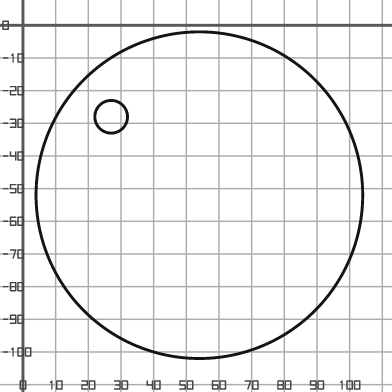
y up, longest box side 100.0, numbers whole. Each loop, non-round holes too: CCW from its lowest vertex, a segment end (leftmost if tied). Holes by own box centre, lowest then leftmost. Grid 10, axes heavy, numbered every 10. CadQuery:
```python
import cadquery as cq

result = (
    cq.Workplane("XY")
    .moveTo(54.0, -52.0)
    .circle(50.0)
    .moveTo(27.0, -28.0)
    .circle(5.0)
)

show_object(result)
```